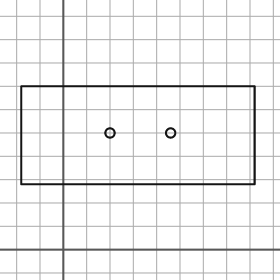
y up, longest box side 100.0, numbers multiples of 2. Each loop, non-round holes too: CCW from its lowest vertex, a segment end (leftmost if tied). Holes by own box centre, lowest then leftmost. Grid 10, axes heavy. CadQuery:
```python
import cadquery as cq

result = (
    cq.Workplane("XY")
    .moveTo(-18.0, 28.0)
    .lineTo(82.0, 28.0)
    .lineTo(82.0, 70.0)
    .lineTo(-18.0, 70.0)
    .close()
    .moveTo(20.0, 50.0)
    .circle(2.0)
    .moveTo(46.0, 50.0)
    .circle(2.0)
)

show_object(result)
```